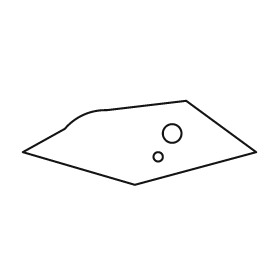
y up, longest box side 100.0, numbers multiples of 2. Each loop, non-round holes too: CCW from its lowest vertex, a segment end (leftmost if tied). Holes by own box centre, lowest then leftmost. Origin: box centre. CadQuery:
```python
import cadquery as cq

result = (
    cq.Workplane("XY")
    .moveTo(-2.0, -18.0)
    .lineTo(50.0, -4.0)
    .lineTo(20.0, 18.0)
    .lineTo(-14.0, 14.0)
    .threePointArc((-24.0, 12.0), (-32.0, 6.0))
    .lineTo(-50.0, -4.0)
    .close()
    .moveTo(8.0, -6.0)
    .circle(2.0)
    .moveTo(14.0, 4.0)
    .circle(4.0)
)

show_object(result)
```